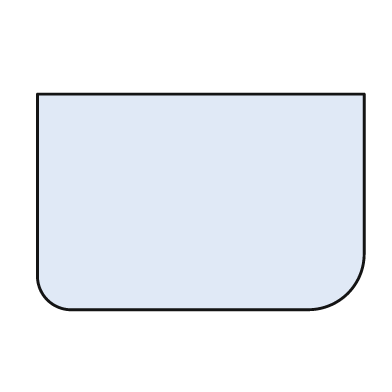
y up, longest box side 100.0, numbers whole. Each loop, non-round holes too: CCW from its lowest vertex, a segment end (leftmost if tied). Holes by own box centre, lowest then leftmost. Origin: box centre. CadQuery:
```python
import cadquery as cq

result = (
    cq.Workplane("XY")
    .moveTo(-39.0, -33.0)
    .lineTo(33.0, -33.0)
    .threePointArc((45.0, -28.0), (50.0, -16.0))
    .lineTo(50.0, 33.0)
    .lineTo(-50.0, 33.0)
    .lineTo(-50.0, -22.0)
    .threePointArc((-47.0, -30.0), (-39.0, -33.0))
    .close()
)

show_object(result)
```